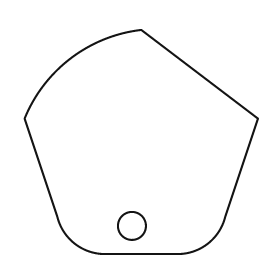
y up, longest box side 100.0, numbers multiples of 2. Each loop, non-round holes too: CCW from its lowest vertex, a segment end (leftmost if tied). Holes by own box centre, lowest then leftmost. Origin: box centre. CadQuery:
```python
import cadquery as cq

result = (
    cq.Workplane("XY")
    .moveTo(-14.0, -48.0)
    .lineTo(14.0, -48.0)
    .threePointArc((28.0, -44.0), (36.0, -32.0))
    .lineTo(50.0, 10.0)
    .lineTo(0.0, 48.0)
    .threePointArc((-30.0, 36.0), (-50.0, 10.0))
    .lineTo(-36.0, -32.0)
    .threePointArc((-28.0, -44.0), (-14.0, -48.0))
    .close()
    .moveTo(-4.0, -36.0)
    .circle(6.0)
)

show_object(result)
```